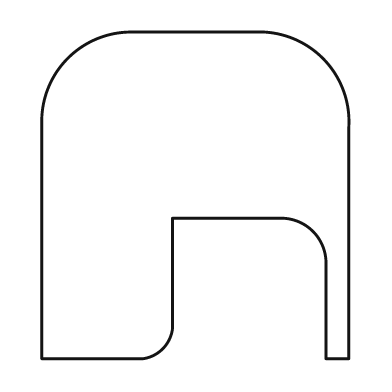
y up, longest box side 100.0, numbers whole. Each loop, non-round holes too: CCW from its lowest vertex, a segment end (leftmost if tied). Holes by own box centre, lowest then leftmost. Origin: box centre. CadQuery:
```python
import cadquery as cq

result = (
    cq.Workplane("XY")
    .moveTo(-47.0, -50.0)
    .lineTo(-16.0, -50.0)
    .threePointArc((-10.0, -47.0), (-7.0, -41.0))
    .lineTo(-7.0, -7.0)
    .lineTo(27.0, -7.0)
    .threePointArc((36.0, -11.0), (40.0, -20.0))
    .lineTo(40.0, -50.0)
    .lineTo(47.0, -50.0)
    .lineTo(47.0, 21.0)
    .threePointArc((39.0, 42.0), (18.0, 50.0))
    .lineTo(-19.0, 50.0)
    .threePointArc((-39.0, 42.0), (-47.0, 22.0))
    .close()
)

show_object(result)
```